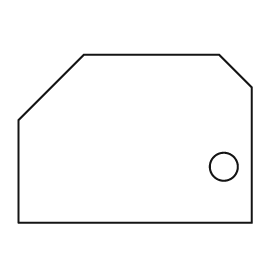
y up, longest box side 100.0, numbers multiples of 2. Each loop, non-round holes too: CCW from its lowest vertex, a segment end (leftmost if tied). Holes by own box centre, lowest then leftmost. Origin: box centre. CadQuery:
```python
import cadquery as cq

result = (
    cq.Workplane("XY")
    .moveTo(-50.0, -36.0)
    .lineTo(50.0, -36.0)
    .lineTo(50.0, 22.0)
    .lineTo(36.0, 36.0)
    .lineTo(-22.0, 36.0)
    .lineTo(-50.0, 8.0)
    .close()
    .moveTo(38.0, -12.0)
    .circle(6.0)
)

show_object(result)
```